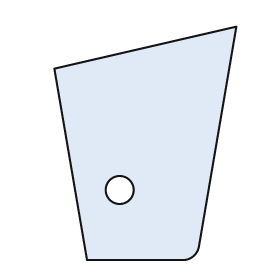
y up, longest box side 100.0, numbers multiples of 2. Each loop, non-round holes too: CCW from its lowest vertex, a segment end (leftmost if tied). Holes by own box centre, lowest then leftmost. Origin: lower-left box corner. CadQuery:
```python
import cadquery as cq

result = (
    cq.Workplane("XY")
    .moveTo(14.0, 0.0)
    .lineTo(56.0, 0.0)
    .threePointArc((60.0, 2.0), (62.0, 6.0))
    .lineTo(78.0, 100.0)
    .lineTo(0.0, 82.0)
    .close()
    .moveTo(28.0, 30.0)
    .circle(6.0)
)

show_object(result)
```